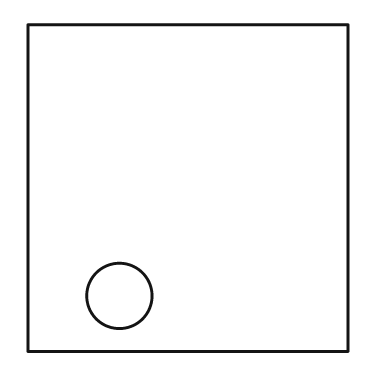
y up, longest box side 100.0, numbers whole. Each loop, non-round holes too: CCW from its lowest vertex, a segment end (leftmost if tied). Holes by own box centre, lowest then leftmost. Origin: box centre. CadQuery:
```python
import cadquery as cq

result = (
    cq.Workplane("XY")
    .moveTo(-49.0, -50.0)
    .lineTo(49.0, -50.0)
    .lineTo(49.0, 50.0)
    .lineTo(-49.0, 50.0)
    .close()
    .moveTo(-21.0, -33.0)
    .circle(10.0)
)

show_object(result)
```